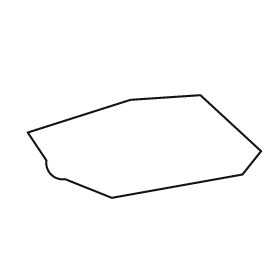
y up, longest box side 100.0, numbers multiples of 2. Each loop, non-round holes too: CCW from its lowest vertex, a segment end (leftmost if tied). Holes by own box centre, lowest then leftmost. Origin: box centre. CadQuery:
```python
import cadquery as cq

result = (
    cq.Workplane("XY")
    .moveTo(-14.0, -22.0)
    .lineTo(42.0, -12.0)
    .lineTo(50.0, -2.0)
    .lineTo(24.0, 22.0)
    .lineTo(-6.0, 20.0)
    .lineTo(-50.0, 6.0)
    .lineTo(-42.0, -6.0)
    .threePointArc((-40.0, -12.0), (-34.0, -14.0))
    .close()
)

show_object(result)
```